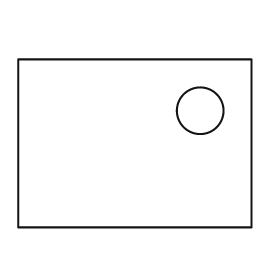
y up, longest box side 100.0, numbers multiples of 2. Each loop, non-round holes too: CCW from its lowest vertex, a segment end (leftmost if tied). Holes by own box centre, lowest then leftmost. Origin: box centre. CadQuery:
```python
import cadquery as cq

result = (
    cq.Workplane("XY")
    .moveTo(-50.0, -36.0)
    .lineTo(50.0, -36.0)
    .lineTo(50.0, 36.0)
    .lineTo(-50.0, 36.0)
    .close()
    .moveTo(28.0, 14.0)
    .circle(10.0)
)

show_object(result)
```